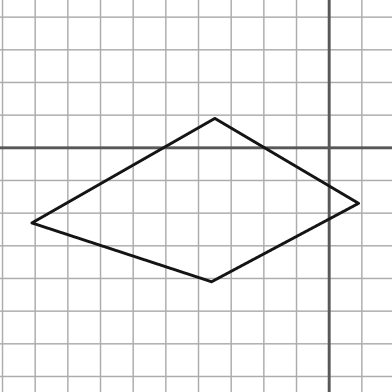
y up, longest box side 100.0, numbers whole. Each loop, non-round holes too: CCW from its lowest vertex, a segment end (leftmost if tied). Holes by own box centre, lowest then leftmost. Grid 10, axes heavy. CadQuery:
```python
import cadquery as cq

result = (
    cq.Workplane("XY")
    .moveTo(-36.0, -41.0)
    .lineTo(9.0, -17.0)
    .lineTo(-35.0, 9.0)
    .lineTo(-91.0, -23.0)
    .close()
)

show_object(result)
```